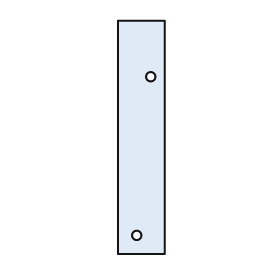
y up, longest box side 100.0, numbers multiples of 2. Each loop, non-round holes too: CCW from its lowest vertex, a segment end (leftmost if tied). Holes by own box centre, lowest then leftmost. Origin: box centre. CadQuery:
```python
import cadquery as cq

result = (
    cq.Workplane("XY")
    .moveTo(-10.0, -50.0)
    .lineTo(10.0, -50.0)
    .lineTo(10.0, 50.0)
    .lineTo(-10.0, 50.0)
    .close()
    .moveTo(-2.0, -42.0)
    .circle(2.0)
    .moveTo(4.0, 26.0)
    .circle(2.0)
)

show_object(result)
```